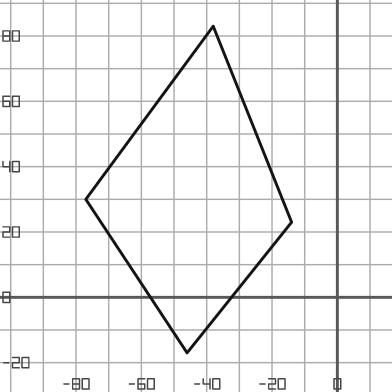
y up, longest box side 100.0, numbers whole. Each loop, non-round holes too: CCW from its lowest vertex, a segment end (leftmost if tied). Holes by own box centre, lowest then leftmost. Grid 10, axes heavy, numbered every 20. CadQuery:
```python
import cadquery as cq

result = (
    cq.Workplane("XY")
    .moveTo(-46.0, -17.0)
    .lineTo(-14.0, 23.0)
    .lineTo(-38.0, 83.0)
    .lineTo(-77.0, 30.0)
    .close()
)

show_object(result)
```